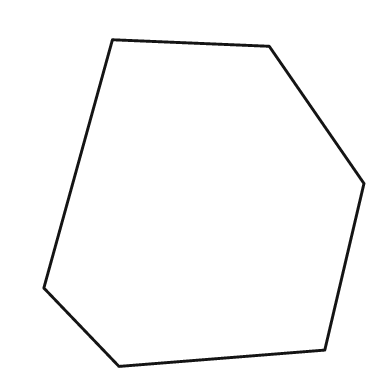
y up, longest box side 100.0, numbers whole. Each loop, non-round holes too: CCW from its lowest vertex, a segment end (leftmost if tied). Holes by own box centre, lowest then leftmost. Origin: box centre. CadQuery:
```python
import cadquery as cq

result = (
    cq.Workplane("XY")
    .moveTo(-26.0, -50.0)
    .lineTo(37.0, -45.0)
    .lineTo(49.0, 6.0)
    .lineTo(20.0, 48.0)
    .lineTo(-28.0, 50.0)
    .lineTo(-49.0, -26.0)
    .close()
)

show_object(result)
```